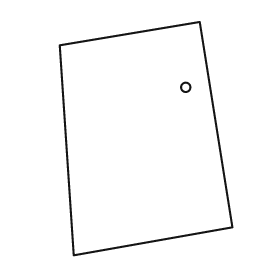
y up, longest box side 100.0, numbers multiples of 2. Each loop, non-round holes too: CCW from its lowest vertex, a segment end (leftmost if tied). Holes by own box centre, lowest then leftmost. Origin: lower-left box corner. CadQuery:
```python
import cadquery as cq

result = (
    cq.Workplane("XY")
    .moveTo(6.0, 0.0)
    .lineTo(74.0, 12.0)
    .lineTo(60.0, 100.0)
    .lineTo(0.0, 90.0)
    .close()
    .moveTo(54.0, 72.0)
    .circle(2.0)
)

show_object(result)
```